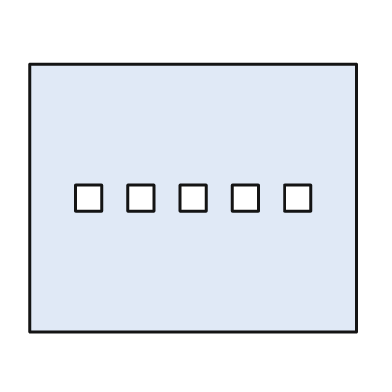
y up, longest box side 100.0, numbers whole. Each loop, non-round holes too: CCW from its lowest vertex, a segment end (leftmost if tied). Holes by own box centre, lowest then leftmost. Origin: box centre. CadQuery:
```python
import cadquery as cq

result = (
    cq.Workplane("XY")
    .moveTo(-50.0, -41.0)
    .lineTo(50.0, -41.0)
    .lineTo(50.0, 41.0)
    .lineTo(-50.0, 41.0)
    .close()
    .moveTo(-36.0, -4.0)
    .lineTo(-28.0, -4.0)
    .lineTo(-28.0, 4.0)
    .lineTo(-36.0, 4.0)
    .close()
    .moveTo(-20.0, -4.0)
    .lineTo(-12.0, -4.0)
    .lineTo(-12.0, 4.0)
    .lineTo(-20.0, 4.0)
    .close()
    .moveTo(-4.0, -4.0)
    .lineTo(4.0, -4.0)
    .lineTo(4.0, 4.0)
    .lineTo(-4.0, 4.0)
    .close()
    .moveTo(12.0, -4.0)
    .lineTo(20.0, -4.0)
    .lineTo(20.0, 4.0)
    .lineTo(12.0, 4.0)
    .close()
    .moveTo(28.0, -4.0)
    .lineTo(36.0, -4.0)
    .lineTo(36.0, 4.0)
    .lineTo(28.0, 4.0)
    .close()
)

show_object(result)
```